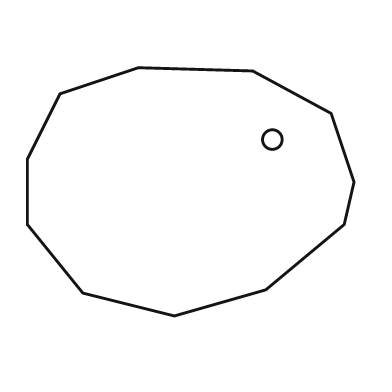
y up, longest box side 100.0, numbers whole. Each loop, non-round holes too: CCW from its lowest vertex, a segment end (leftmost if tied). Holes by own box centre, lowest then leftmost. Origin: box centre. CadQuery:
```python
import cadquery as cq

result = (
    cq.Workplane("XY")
    .moveTo(-5.0, -38.0)
    .lineTo(23.0, -30.0)
    .lineTo(47.0, -10.0)
    .lineTo(50.0, 3.0)
    .lineTo(43.0, 24.0)
    .lineTo(19.0, 37.0)
    .lineTo(-16.0, 38.0)
    .lineTo(-40.0, 30.0)
    .lineTo(-50.0, 10.0)
    .lineTo(-50.0, -10.0)
    .lineTo(-33.0, -31.0)
    .close()
    .moveTo(25.0, 16.0)
    .circle(3.0)
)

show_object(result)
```